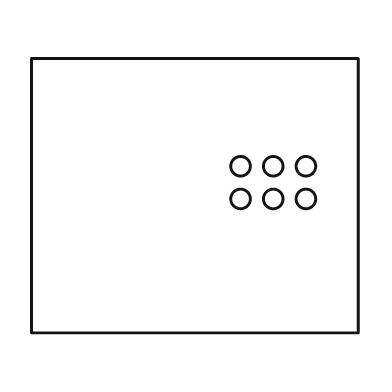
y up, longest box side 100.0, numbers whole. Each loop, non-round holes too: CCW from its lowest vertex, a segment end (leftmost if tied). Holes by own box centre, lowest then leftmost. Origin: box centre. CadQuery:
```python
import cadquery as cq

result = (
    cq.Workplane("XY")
    .moveTo(-50.0, -42.0)
    .lineTo(50.0, -42.0)
    .lineTo(50.0, 42.0)
    .lineTo(-50.0, 42.0)
    .close()
    .moveTo(14.0, -1.0)
    .circle(3.0)
    .moveTo(24.0, -1.0)
    .circle(3.0)
    .moveTo(34.0, -1.0)
    .circle(3.0)
    .moveTo(14.0, 9.0)
    .circle(3.0)
    .moveTo(24.0, 9.0)
    .circle(3.0)
    .moveTo(34.0, 9.0)
    .circle(3.0)
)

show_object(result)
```